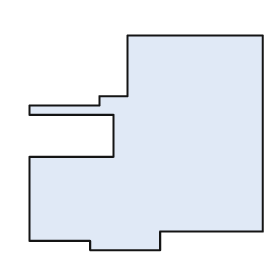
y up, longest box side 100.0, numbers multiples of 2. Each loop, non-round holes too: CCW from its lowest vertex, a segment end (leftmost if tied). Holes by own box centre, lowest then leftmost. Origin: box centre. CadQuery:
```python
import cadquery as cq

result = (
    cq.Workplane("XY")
    .moveTo(-24.0, -46.0)
    .lineTo(6.0, -46.0)
    .lineTo(6.0, -38.0)
    .lineTo(50.0, -38.0)
    .lineTo(50.0, 46.0)
    .lineTo(-8.0, 46.0)
    .lineTo(-8.0, 20.0)
    .lineTo(-20.0, 20.0)
    .lineTo(-20.0, 16.0)
    .lineTo(-50.0, 16.0)
    .lineTo(-50.0, 12.0)
    .lineTo(-14.0, 12.0)
    .lineTo(-14.0, -6.0)
    .lineTo(-50.0, -6.0)
    .lineTo(-50.0, -42.0)
    .lineTo(-24.0, -42.0)
    .close()
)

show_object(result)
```